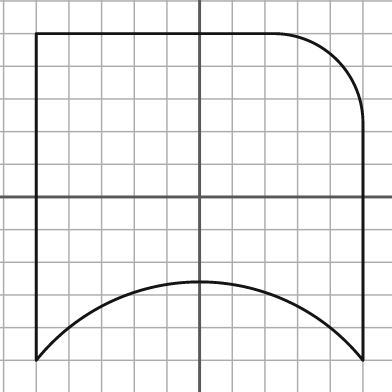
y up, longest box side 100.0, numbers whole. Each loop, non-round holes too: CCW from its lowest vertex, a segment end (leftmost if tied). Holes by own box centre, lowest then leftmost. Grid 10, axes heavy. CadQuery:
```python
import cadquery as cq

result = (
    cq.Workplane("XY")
    .moveTo(-50.0, -50.0)
    .threePointArc((0.0, -26.0), (50.0, -50.0))
    .lineTo(50.0, 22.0)
    .threePointArc((42.0, 42.0), (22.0, 50.0))
    .lineTo(-50.0, 50.0)
    .close()
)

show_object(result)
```